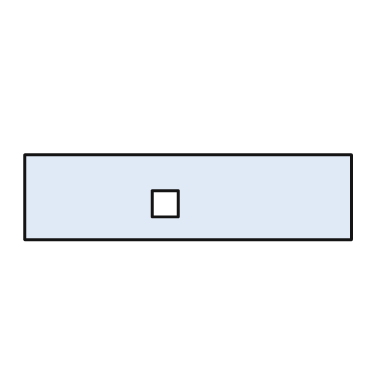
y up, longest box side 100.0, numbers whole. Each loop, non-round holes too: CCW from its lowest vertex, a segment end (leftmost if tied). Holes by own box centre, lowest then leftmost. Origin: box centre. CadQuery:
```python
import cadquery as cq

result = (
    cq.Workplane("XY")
    .moveTo(-50.0, -13.0)
    .lineTo(50.0, -13.0)
    .lineTo(50.0, 13.0)
    .lineTo(-50.0, 13.0)
    .close()
    .moveTo(-11.0, -6.0)
    .lineTo(-3.0, -6.0)
    .lineTo(-3.0, 2.0)
    .lineTo(-11.0, 2.0)
    .close()
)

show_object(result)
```